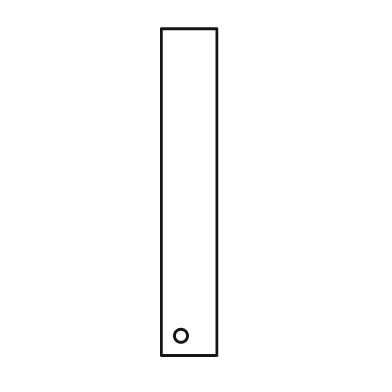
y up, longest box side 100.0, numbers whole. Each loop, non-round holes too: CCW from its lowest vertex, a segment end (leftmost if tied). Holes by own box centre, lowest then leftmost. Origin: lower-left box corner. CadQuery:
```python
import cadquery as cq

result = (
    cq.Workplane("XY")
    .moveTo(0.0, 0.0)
    .lineTo(17.0, 0.0)
    .lineTo(17.0, 100.0)
    .lineTo(0.0, 100.0)
    .close()
    .moveTo(6.0, 6.0)
    .circle(2.0)
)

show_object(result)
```